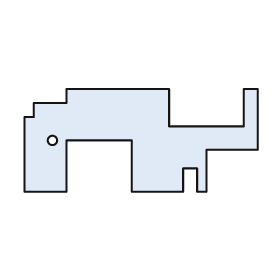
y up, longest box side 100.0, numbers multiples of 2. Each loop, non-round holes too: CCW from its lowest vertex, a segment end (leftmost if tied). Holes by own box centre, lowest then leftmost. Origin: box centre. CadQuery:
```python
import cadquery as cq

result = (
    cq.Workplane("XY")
    .moveTo(-50.0, -22.0)
    .lineTo(-32.0, -22.0)
    .lineTo(-32.0, 0.0)
    .lineTo(-4.0, 0.0)
    .lineTo(-4.0, -22.0)
    .lineTo(18.0, -22.0)
    .lineTo(18.0, -12.0)
    .lineTo(24.0, -12.0)
    .lineTo(24.0, -22.0)
    .lineTo(28.0, -22.0)
    .lineTo(28.0, -4.0)
    .lineTo(50.0, -4.0)
    .lineTo(50.0, 22.0)
    .lineTo(44.0, 22.0)
    .lineTo(44.0, 6.0)
    .lineTo(12.0, 6.0)
    .lineTo(12.0, 22.0)
    .lineTo(-32.0, 22.0)
    .lineTo(-32.0, 16.0)
    .lineTo(-46.0, 16.0)
    .lineTo(-46.0, 10.0)
    .lineTo(-50.0, 10.0)
    .close()
    .moveTo(-38.0, 0.0)
    .circle(2.0)
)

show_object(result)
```